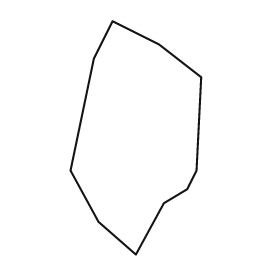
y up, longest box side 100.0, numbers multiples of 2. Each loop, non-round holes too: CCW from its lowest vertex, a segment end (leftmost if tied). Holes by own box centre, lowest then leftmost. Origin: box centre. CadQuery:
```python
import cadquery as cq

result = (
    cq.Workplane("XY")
    .moveTo(0.0, -50.0)
    .lineTo(12.0, -28.0)
    .lineTo(22.0, -22.0)
    .lineTo(26.0, -14.0)
    .lineTo(28.0, 26.0)
    .lineTo(10.0, 40.0)
    .lineTo(-10.0, 50.0)
    .lineTo(-18.0, 34.0)
    .lineTo(-28.0, -14.0)
    .lineTo(-16.0, -36.0)
    .close()
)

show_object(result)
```